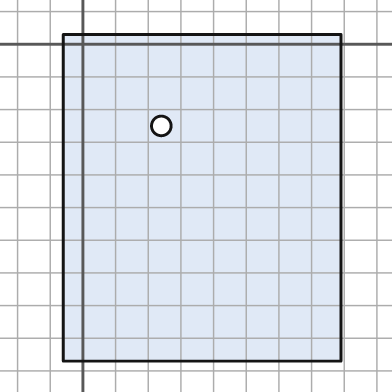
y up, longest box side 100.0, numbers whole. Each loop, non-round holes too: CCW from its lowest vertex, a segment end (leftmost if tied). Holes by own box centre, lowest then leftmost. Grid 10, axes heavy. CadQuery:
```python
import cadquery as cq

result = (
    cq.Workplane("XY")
    .moveTo(-6.0, -97.0)
    .lineTo(79.0, -97.0)
    .lineTo(79.0, 3.0)
    .lineTo(-6.0, 3.0)
    .close()
    .moveTo(24.0, -25.0)
    .circle(3.0)
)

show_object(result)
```